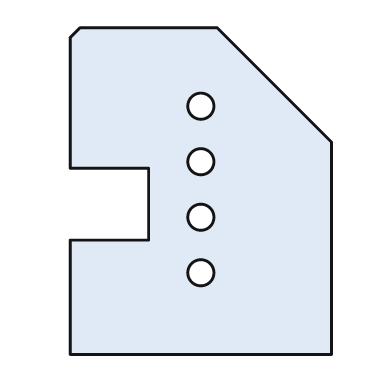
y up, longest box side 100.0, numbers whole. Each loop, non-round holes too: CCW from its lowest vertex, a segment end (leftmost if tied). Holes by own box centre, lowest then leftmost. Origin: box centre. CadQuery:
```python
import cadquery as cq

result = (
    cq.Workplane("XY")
    .moveTo(-40.0, -50.0)
    .lineTo(40.0, -50.0)
    .lineTo(40.0, 15.0)
    .lineTo(5.0, 50.0)
    .lineTo(-37.0, 50.0)
    .lineTo(-40.0, 47.0)
    .lineTo(-40.0, 7.0)
    .lineTo(-16.0, 7.0)
    .lineTo(-16.0, -15.0)
    .lineTo(-40.0, -15.0)
    .close()
    .moveTo(0.0, -25.0)
    .circle(4.0)
    .moveTo(0.0, -8.0)
    .circle(4.0)
    .moveTo(0.0, 9.0)
    .circle(4.0)
    .moveTo(0.0, 26.0)
    .circle(4.0)
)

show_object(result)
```